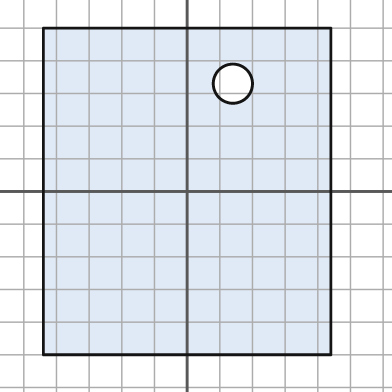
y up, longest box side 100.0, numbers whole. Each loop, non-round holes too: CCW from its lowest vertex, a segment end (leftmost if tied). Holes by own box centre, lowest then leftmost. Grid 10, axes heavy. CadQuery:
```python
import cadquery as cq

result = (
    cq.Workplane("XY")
    .moveTo(-44.0, -50.0)
    .lineTo(44.0, -50.0)
    .lineTo(44.0, 50.0)
    .lineTo(-44.0, 50.0)
    .close()
    .moveTo(14.0, 33.0)
    .circle(6.0)
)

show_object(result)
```